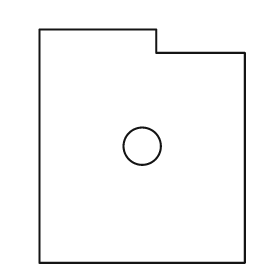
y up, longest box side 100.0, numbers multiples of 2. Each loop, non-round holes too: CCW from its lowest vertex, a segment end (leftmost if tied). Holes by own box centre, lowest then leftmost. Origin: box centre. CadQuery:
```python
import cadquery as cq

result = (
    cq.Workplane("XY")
    .moveTo(-44.0, -50.0)
    .lineTo(44.0, -50.0)
    .lineTo(44.0, 40.0)
    .lineTo(6.0, 40.0)
    .lineTo(6.0, 50.0)
    .lineTo(-44.0, 50.0)
    .close()
    .moveTo(0.0, 0.0)
    .circle(8.0)
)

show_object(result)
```